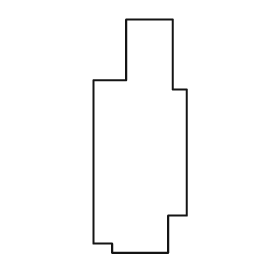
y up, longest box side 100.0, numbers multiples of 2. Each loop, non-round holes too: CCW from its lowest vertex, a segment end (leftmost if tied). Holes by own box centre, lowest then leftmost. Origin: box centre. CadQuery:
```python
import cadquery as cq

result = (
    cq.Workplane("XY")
    .moveTo(-12.0, -50.0)
    .lineTo(12.0, -50.0)
    .lineTo(12.0, -34.0)
    .lineTo(20.0, -34.0)
    .lineTo(20.0, 20.0)
    .lineTo(14.0, 20.0)
    .lineTo(14.0, 50.0)
    .lineTo(-6.0, 50.0)
    .lineTo(-6.0, 24.0)
    .lineTo(-20.0, 24.0)
    .lineTo(-20.0, -46.0)
    .lineTo(-12.0, -46.0)
    .close()
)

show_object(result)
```